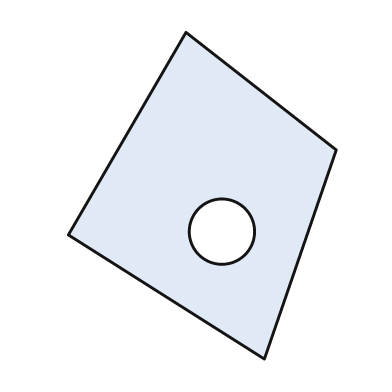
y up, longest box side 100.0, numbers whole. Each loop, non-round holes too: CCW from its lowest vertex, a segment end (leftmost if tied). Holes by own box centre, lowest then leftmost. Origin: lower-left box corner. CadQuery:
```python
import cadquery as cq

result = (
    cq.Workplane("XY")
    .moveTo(60.0, 0.0)
    .lineTo(82.0, 64.0)
    .lineTo(36.0, 100.0)
    .lineTo(0.0, 38.0)
    .close()
    .moveTo(47.0, 39.0)
    .circle(10.0)
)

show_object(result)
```